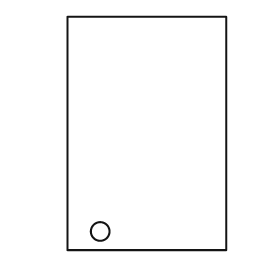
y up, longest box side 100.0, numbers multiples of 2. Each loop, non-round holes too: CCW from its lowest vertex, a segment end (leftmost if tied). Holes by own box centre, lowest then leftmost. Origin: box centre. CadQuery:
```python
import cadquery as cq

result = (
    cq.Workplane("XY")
    .moveTo(-34.0, -50.0)
    .lineTo(34.0, -50.0)
    .lineTo(34.0, 50.0)
    .lineTo(-34.0, 50.0)
    .close()
    .moveTo(-20.0, -42.0)
    .circle(4.0)
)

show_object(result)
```